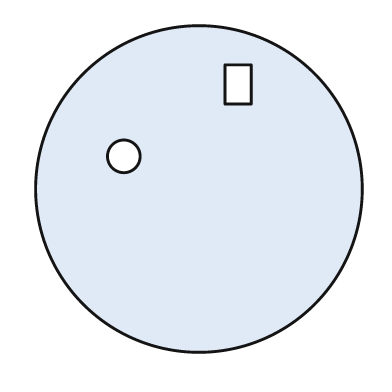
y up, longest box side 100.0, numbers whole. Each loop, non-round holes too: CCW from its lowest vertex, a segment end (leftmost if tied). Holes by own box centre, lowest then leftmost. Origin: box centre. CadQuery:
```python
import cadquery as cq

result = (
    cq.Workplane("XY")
    .moveTo(0.0, 0.0)
    .circle(50.0)
    .moveTo(-23.0, 10.0)
    .circle(5.0)
    .moveTo(8.0, 26.0)
    .lineTo(16.0, 26.0)
    .lineTo(16.0, 38.0)
    .lineTo(8.0, 38.0)
    .close()
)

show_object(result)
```